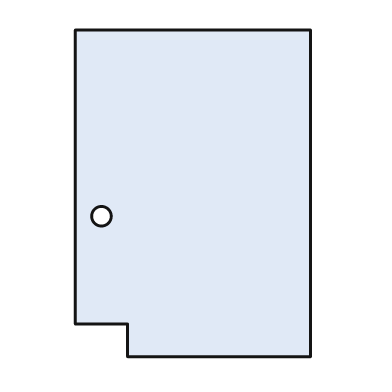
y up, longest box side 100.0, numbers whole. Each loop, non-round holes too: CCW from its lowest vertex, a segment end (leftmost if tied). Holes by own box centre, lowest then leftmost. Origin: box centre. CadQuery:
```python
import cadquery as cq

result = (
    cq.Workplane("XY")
    .moveTo(-20.0, -50.0)
    .lineTo(36.0, -50.0)
    .lineTo(36.0, 50.0)
    .lineTo(-36.0, 50.0)
    .lineTo(-36.0, -40.0)
    .lineTo(-20.0, -40.0)
    .close()
    .moveTo(-28.0, -7.0)
    .circle(3.0)
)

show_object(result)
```